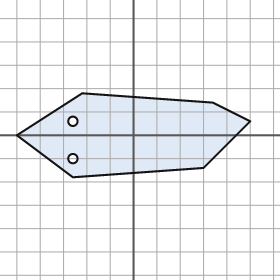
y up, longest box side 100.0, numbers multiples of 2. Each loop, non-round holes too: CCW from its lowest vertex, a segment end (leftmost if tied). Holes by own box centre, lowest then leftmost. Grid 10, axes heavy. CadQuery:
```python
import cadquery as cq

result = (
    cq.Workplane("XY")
    .moveTo(-26.0, -18.0)
    .lineTo(30.0, -14.0)
    .lineTo(50.0, 6.0)
    .lineTo(34.0, 14.0)
    .lineTo(-22.0, 18.0)
    .lineTo(-50.0, 0.0)
    .close()
    .moveTo(-26.0, -10.0)
    .circle(2.0)
    .moveTo(-26.0, 6.0)
    .circle(2.0)
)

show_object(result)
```